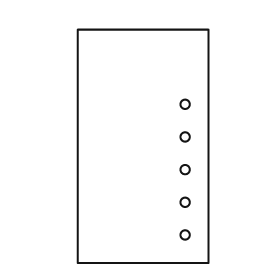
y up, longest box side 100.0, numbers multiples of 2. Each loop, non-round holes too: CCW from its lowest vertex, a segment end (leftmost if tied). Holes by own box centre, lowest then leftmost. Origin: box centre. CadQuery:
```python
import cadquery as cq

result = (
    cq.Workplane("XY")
    .moveTo(-28.0, -50.0)
    .lineTo(28.0, -50.0)
    .lineTo(28.0, 50.0)
    .lineTo(-28.0, 50.0)
    .close()
    .moveTo(18.0, -38.0)
    .circle(2.0)
    .moveTo(18.0, -24.0)
    .circle(2.0)
    .moveTo(18.0, -10.0)
    .circle(2.0)
    .moveTo(18.0, 4.0)
    .circle(2.0)
    .moveTo(18.0, 18.0)
    .circle(2.0)
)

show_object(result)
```